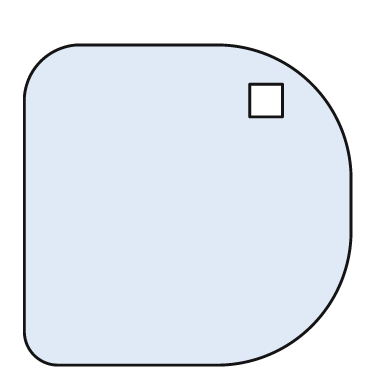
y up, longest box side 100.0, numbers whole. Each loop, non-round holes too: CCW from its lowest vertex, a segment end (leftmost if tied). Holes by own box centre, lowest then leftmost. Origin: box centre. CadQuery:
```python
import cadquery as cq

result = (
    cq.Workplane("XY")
    .moveTo(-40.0, -49.0)
    .lineTo(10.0, -49.0)
    .threePointArc((38.0, -37.0), (50.0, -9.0))
    .lineTo(50.0, 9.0)
    .threePointArc((38.0, 37.0), (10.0, 49.0))
    .lineTo(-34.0, 49.0)
    .threePointArc((-45.0, 44.0), (-50.0, 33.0))
    .lineTo(-50.0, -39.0)
    .threePointArc((-47.0, -46.0), (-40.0, -49.0))
    .close()
    .moveTo(19.0, 27.0)
    .lineTo(29.0, 27.0)
    .lineTo(29.0, 37.0)
    .lineTo(19.0, 37.0)
    .close()
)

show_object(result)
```